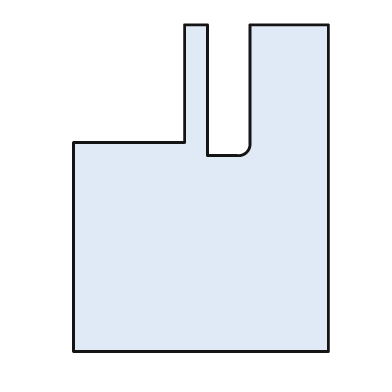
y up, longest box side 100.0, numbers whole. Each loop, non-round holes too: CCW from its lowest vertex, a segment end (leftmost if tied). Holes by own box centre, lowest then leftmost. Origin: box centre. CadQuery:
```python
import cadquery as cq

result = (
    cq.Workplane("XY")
    .moveTo(-39.0, -50.0)
    .lineTo(39.0, -50.0)
    .lineTo(39.0, 50.0)
    .lineTo(15.0, 50.0)
    .lineTo(15.0, 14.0)
    .threePointArc((14.0, 11.0), (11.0, 10.0))
    .lineTo(2.0, 10.0)
    .lineTo(2.0, 50.0)
    .lineTo(-5.0, 50.0)
    .lineTo(-5.0, 14.0)
    .lineTo(-39.0, 14.0)
    .close()
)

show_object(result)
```